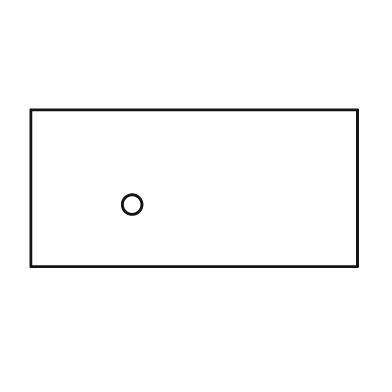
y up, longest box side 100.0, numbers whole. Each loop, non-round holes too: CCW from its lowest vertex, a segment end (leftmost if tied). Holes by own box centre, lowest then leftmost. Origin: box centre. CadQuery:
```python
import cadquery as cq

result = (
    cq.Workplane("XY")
    .moveTo(-50.0, -24.0)
    .lineTo(50.0, -24.0)
    .lineTo(50.0, 24.0)
    .lineTo(-50.0, 24.0)
    .close()
    .moveTo(-19.0, -5.0)
    .circle(3.0)
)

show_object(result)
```